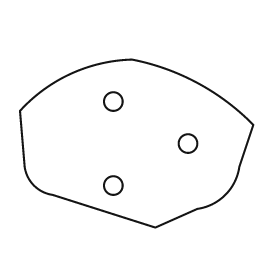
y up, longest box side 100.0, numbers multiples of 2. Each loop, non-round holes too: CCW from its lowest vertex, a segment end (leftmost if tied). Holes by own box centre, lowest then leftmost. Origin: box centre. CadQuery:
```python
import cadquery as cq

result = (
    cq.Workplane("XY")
    .moveTo(8.0, -36.0)
    .lineTo(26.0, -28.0)
    .threePointArc((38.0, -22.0), (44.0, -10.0))
    .lineTo(50.0, 8.0)
    .threePointArc((26.0, 26.0), (-2.0, 36.0))
    .threePointArc((-28.0, 30.0), (-50.0, 14.0))
    .lineTo(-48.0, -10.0)
    .threePointArc((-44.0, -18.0), (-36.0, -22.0))
    .close()
    .moveTo(-10.0, -18.0)
    .circle(4.0)
    .moveTo(22.0, 0.0)
    .circle(4.0)
    .moveTo(-10.0, 18.0)
    .circle(4.0)
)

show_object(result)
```